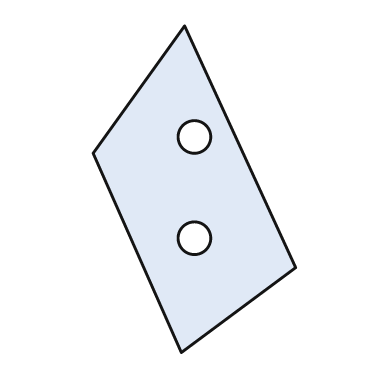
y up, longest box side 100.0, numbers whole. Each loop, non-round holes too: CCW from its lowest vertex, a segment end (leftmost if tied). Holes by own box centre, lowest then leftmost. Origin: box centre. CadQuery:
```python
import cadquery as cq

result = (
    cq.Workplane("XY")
    .moveTo(-4.0, -50.0)
    .lineTo(31.0, -24.0)
    .lineTo(-3.0, 50.0)
    .lineTo(-31.0, 11.0)
    .close()
    .moveTo(0.0, -15.0)
    .circle(5.0)
    .moveTo(0.0, 16.0)
    .circle(5.0)
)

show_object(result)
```